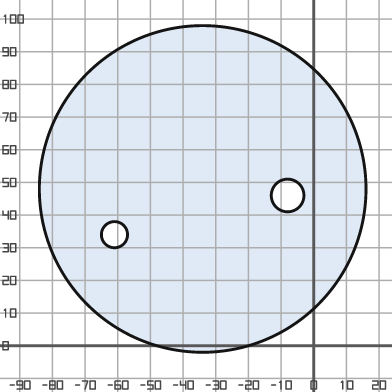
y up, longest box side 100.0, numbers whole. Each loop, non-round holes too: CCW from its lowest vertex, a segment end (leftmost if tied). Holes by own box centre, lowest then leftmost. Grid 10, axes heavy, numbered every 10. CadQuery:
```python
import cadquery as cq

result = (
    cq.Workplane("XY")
    .moveTo(-34.0, 48.0)
    .circle(50.0)
    .moveTo(-61.0, 34.0)
    .circle(4.0)
    .moveTo(-8.0, 46.0)
    .circle(5.0)
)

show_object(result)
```